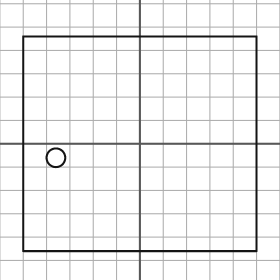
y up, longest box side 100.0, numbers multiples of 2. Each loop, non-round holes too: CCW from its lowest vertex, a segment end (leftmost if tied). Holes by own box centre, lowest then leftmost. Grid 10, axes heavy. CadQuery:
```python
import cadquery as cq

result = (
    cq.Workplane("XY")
    .moveTo(-50.0, -46.0)
    .lineTo(50.0, -46.0)
    .lineTo(50.0, 46.0)
    .lineTo(-50.0, 46.0)
    .close()
    .moveTo(-36.0, -6.0)
    .circle(4.0)
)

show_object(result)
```